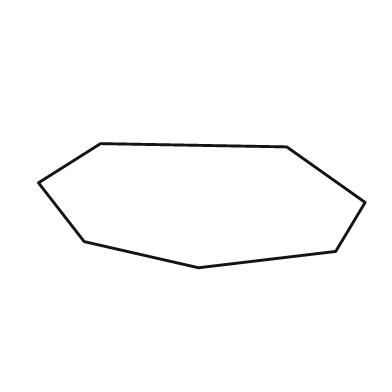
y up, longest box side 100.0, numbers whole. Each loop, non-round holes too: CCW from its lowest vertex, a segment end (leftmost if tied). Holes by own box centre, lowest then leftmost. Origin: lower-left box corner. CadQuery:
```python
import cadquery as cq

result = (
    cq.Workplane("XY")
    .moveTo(49.0, 0.0)
    .lineTo(91.0, 5.0)
    .lineTo(100.0, 20.0)
    .lineTo(76.0, 37.0)
    .lineTo(19.0, 38.0)
    .lineTo(0.0, 26.0)
    .lineTo(14.0, 8.0)
    .close()
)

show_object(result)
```